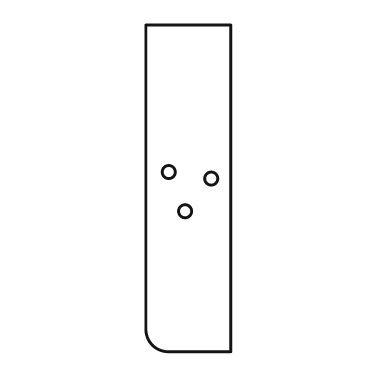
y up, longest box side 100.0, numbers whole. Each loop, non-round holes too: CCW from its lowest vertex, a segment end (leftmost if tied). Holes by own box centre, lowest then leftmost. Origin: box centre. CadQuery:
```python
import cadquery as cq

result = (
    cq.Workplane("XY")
    .moveTo(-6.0, -50.0)
    .lineTo(13.0, -50.0)
    .lineTo(13.0, 50.0)
    .lineTo(-13.0, 50.0)
    .lineTo(-13.0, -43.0)
    .threePointArc((-11.0, -48.0), (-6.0, -50.0))
    .close()
    .moveTo(-1.0, -7.0)
    .circle(2.0)
    .moveTo(7.0, 3.0)
    .circle(2.0)
    .moveTo(-6.0, 5.0)
    .circle(2.0)
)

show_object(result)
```